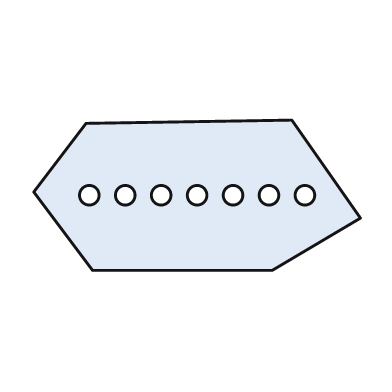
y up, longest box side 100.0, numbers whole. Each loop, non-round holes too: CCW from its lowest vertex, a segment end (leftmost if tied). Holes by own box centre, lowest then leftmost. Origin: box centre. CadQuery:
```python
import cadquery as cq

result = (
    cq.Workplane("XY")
    .moveTo(-32.0, -23.0)
    .lineTo(23.0, -23.0)
    .lineTo(50.0, -7.0)
    .lineTo(29.0, 23.0)
    .lineTo(-34.0, 22.0)
    .lineTo(-50.0, 1.0)
    .close()
    .moveTo(-33.0, 0.0)
    .circle(3.0)
    .moveTo(-22.0, 0.0)
    .circle(3.0)
    .moveTo(-11.0, 0.0)
    .circle(3.0)
    .moveTo(0.0, 0.0)
    .circle(3.0)
    .moveTo(11.0, 0.0)
    .circle(3.0)
    .moveTo(22.0, 0.0)
    .circle(3.0)
    .moveTo(33.0, 0.0)
    .circle(3.0)
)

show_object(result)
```